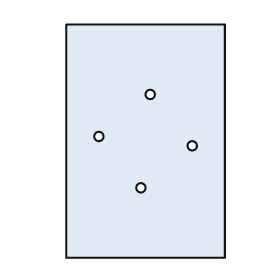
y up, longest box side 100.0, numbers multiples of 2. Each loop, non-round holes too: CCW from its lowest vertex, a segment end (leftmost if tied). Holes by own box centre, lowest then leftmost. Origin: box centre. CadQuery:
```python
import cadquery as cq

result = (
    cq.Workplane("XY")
    .moveTo(-34.0, -50.0)
    .lineTo(34.0, -50.0)
    .lineTo(34.0, 50.0)
    .lineTo(-34.0, 50.0)
    .close()
    .moveTo(-2.0, -20.0)
    .circle(2.0)
    .moveTo(20.0, -2.0)
    .circle(2.0)
    .moveTo(-20.0, 2.0)
    .circle(2.0)
    .moveTo(2.0, 20.0)
    .circle(2.0)
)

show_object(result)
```